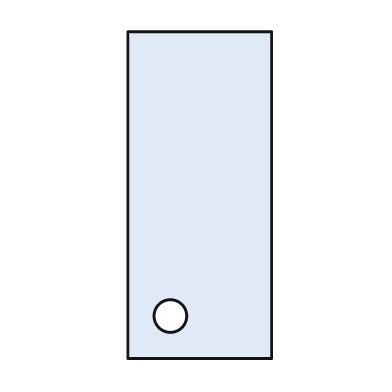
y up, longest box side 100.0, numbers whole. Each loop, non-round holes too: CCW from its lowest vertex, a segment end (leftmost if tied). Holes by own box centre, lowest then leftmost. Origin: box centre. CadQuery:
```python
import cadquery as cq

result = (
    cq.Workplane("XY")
    .moveTo(-22.0, -50.0)
    .lineTo(22.0, -50.0)
    .lineTo(22.0, 50.0)
    .lineTo(-22.0, 50.0)
    .close()
    .moveTo(-9.0, -37.0)
    .circle(5.0)
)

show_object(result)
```